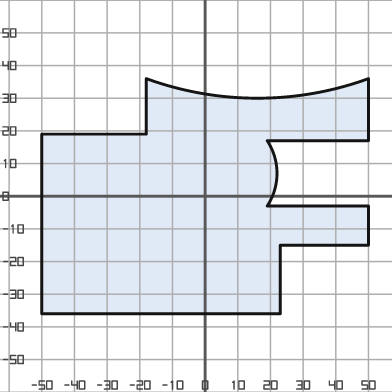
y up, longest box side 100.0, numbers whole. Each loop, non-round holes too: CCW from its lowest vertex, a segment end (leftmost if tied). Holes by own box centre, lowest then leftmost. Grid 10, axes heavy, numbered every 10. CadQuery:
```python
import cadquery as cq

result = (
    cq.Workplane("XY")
    .moveTo(-50.0, -36.0)
    .lineTo(23.0, -36.0)
    .lineTo(23.0, -15.0)
    .lineTo(50.0, -15.0)
    .lineTo(50.0, -3.0)
    .lineTo(19.0, -3.0)
    .threePointArc((22.0, 7.0), (19.0, 17.0))
    .lineTo(50.0, 17.0)
    .lineTo(50.0, 36.0)
    .threePointArc((16.0, 30.0), (-18.0, 36.0))
    .lineTo(-18.0, 19.0)
    .lineTo(-50.0, 19.0)
    .close()
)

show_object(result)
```